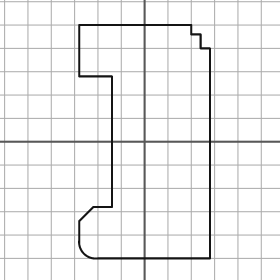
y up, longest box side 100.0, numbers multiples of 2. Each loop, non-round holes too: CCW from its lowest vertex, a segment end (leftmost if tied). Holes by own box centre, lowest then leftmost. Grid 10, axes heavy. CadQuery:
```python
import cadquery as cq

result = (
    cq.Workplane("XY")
    .moveTo(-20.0, -50.0)
    .lineTo(28.0, -50.0)
    .lineTo(28.0, 40.0)
    .lineTo(24.0, 40.0)
    .lineTo(24.0, 46.0)
    .lineTo(20.0, 46.0)
    .lineTo(20.0, 50.0)
    .lineTo(-28.0, 50.0)
    .lineTo(-28.0, 28.0)
    .lineTo(-14.0, 28.0)
    .lineTo(-14.0, -28.0)
    .lineTo(-22.0, -28.0)
    .lineTo(-28.0, -34.0)
    .lineTo(-28.0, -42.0)
    .threePointArc((-26.0, -48.0), (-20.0, -50.0))
    .close()
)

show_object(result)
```